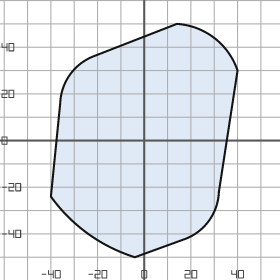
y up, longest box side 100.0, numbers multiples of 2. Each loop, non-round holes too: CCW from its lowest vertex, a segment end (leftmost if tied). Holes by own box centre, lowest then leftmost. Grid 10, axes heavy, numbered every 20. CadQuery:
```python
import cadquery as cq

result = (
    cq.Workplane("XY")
    .moveTo(-4.0, -50.0)
    .lineTo(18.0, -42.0)
    .threePointArc((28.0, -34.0), (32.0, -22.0))
    .lineTo(40.0, 30.0)
    .threePointArc((30.0, 44.0), (14.0, 50.0))
    .lineTo(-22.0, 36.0)
    .threePointArc((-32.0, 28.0), (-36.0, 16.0))
    .lineTo(-40.0, -24.0)
    .threePointArc((-24.0, -40.0), (-4.0, -50.0))
    .close()
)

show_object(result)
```